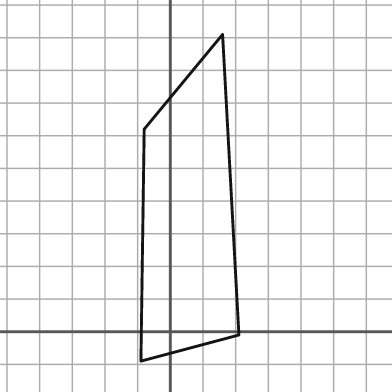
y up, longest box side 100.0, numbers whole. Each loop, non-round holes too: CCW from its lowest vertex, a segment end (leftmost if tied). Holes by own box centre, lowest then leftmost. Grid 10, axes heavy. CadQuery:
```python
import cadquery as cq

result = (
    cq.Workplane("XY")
    .moveTo(-9.0, -9.0)
    .lineTo(21.0, -1.0)
    .lineTo(16.0, 91.0)
    .lineTo(-8.0, 62.0)
    .close()
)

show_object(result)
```